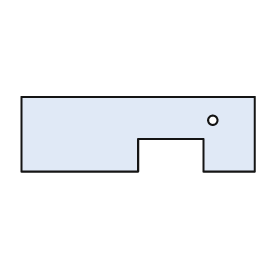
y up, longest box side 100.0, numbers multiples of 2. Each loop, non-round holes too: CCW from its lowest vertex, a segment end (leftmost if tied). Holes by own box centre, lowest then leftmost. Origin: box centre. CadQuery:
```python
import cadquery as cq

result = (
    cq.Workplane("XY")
    .moveTo(-50.0, -16.0)
    .lineTo(0.0, -16.0)
    .lineTo(0.0, -2.0)
    .lineTo(28.0, -2.0)
    .lineTo(28.0, -16.0)
    .lineTo(50.0, -16.0)
    .lineTo(50.0, 16.0)
    .lineTo(-50.0, 16.0)
    .close()
    .moveTo(32.0, 6.0)
    .circle(2.0)
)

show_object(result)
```